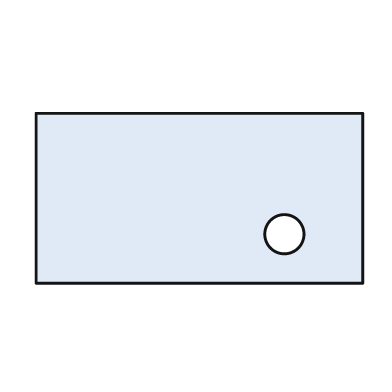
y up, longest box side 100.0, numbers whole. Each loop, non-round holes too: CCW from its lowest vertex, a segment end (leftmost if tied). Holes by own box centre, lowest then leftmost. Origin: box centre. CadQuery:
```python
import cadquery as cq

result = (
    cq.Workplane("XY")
    .moveTo(-50.0, -26.0)
    .lineTo(50.0, -26.0)
    .lineTo(50.0, 26.0)
    .lineTo(-50.0, 26.0)
    .close()
    .moveTo(26.0, -11.0)
    .circle(6.0)
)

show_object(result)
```